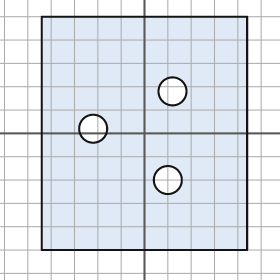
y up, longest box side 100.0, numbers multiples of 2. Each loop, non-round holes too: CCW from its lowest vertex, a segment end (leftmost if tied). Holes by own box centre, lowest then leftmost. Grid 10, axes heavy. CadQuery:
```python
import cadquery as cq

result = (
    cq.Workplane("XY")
    .moveTo(-44.0, -50.0)
    .lineTo(44.0, -50.0)
    .lineTo(44.0, 50.0)
    .lineTo(-44.0, 50.0)
    .close()
    .moveTo(10.0, -20.0)
    .circle(6.0)
    .moveTo(-22.0, 2.0)
    .circle(6.0)
    .moveTo(12.0, 18.0)
    .circle(6.0)
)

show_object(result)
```